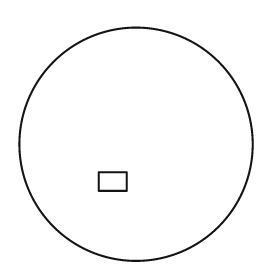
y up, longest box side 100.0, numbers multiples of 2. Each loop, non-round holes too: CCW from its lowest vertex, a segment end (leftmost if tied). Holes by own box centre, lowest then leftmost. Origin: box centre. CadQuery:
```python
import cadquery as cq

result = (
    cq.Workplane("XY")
    .moveTo(0.0, 0.0)
    .circle(50.0)
    .moveTo(-16.0, -20.0)
    .lineTo(-4.0, -20.0)
    .lineTo(-4.0, -12.0)
    .lineTo(-16.0, -12.0)
    .close()
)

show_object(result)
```